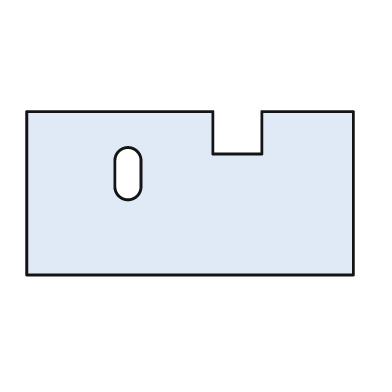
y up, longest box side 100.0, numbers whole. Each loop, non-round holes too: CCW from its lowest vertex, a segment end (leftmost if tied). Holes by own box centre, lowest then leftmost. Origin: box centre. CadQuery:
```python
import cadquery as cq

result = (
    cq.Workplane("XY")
    .moveTo(-50.0, -25.0)
    .lineTo(50.0, -25.0)
    .lineTo(50.0, 25.0)
    .lineTo(22.0, 25.0)
    .lineTo(22.0, 12.0)
    .lineTo(7.0, 12.0)
    .lineTo(7.0, 25.0)
    .lineTo(-50.0, 25.0)
    .close()
    .moveTo(-23.0, 2.0)
    .threePointArc((-19.0, -2.0), (-15.0, 2.0))
    .lineTo(-15.0, 10.0)
    .threePointArc((-19.0, 14.0), (-23.0, 10.0))
    .close()
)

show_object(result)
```